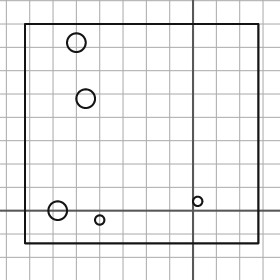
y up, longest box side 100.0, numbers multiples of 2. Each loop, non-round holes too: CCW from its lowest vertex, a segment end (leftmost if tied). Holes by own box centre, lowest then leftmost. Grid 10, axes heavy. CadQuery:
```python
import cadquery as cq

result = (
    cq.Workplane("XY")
    .moveTo(-72.0, -14.0)
    .lineTo(28.0, -14.0)
    .lineTo(28.0, 80.0)
    .lineTo(-72.0, 80.0)
    .close()
    .moveTo(-40.0, -4.0)
    .circle(2.0)
    .moveTo(-58.0, 0.0)
    .circle(4.0)
    .moveTo(2.0, 4.0)
    .circle(2.0)
    .moveTo(-46.0, 48.0)
    .circle(4.0)
    .moveTo(-50.0, 72.0)
    .circle(4.0)
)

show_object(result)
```